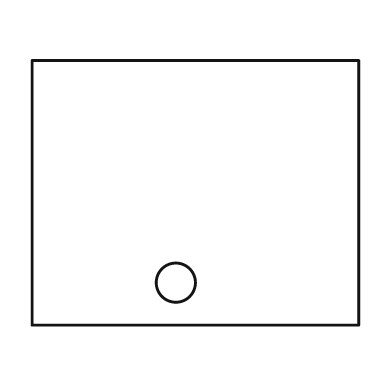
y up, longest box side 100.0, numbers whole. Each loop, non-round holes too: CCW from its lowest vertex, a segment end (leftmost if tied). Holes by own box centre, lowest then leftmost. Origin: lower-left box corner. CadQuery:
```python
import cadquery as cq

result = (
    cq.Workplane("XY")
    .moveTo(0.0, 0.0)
    .lineTo(100.0, 0.0)
    .lineTo(100.0, 81.0)
    .lineTo(0.0, 81.0)
    .close()
    .moveTo(44.0, 13.0)
    .circle(6.0)
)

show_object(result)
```